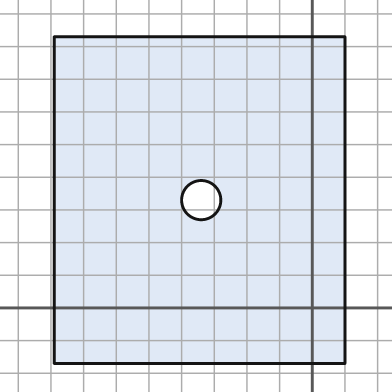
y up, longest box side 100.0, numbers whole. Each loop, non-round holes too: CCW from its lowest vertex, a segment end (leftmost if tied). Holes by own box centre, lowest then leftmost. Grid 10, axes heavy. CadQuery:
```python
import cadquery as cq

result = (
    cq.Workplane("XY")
    .moveTo(-79.0, -17.0)
    .lineTo(10.0, -17.0)
    .lineTo(10.0, 83.0)
    .lineTo(-79.0, 83.0)
    .close()
    .moveTo(-34.0, 33.0)
    .circle(6.0)
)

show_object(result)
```